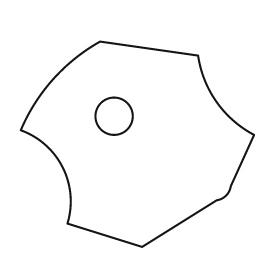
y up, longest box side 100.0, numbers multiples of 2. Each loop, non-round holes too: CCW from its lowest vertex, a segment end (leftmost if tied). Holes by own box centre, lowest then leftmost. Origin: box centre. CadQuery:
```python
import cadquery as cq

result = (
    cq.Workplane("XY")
    .moveTo(2.0, -44.0)
    .lineTo(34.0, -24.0)
    .threePointArc((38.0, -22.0), (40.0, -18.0))
    .lineTo(50.0, 4.0)
    .threePointArc((34.0, 18.0), (26.0, 38.0))
    .lineTo(-16.0, 44.0)
    .threePointArc((-36.0, 28.0), (-50.0, 6.0))
    .threePointArc((-32.0, -10.0), (-30.0, -34.0))
    .close()
    .moveTo(-10.0, 12.0)
    .circle(8.0)
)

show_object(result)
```